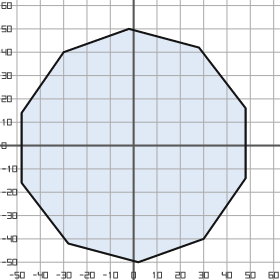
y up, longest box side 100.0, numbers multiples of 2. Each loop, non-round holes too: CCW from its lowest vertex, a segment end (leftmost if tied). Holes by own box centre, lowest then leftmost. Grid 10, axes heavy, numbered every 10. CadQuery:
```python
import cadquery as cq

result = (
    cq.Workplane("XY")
    .moveTo(2.0, -50.0)
    .lineTo(30.0, -40.0)
    .lineTo(48.0, -14.0)
    .lineTo(48.0, 16.0)
    .lineTo(28.0, 42.0)
    .lineTo(-2.0, 50.0)
    .lineTo(-30.0, 40.0)
    .lineTo(-48.0, 14.0)
    .lineTo(-48.0, -16.0)
    .lineTo(-28.0, -42.0)
    .close()
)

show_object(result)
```